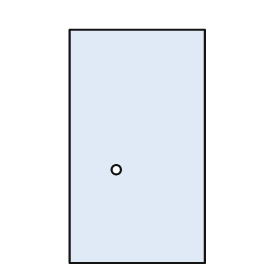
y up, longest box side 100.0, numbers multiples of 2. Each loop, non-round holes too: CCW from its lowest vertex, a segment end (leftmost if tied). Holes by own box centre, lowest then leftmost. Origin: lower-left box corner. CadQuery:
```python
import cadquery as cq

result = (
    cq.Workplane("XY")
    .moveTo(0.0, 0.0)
    .lineTo(58.0, 0.0)
    .lineTo(58.0, 100.0)
    .lineTo(0.0, 100.0)
    .close()
    .moveTo(20.0, 40.0)
    .circle(2.0)
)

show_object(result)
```